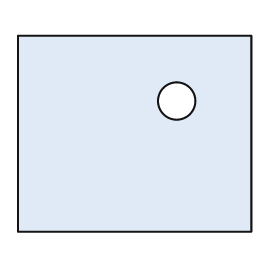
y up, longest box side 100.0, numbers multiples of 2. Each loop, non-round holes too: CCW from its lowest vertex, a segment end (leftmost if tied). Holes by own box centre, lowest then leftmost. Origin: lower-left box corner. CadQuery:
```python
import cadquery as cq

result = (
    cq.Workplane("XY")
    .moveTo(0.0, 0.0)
    .lineTo(100.0, 0.0)
    .lineTo(100.0, 84.0)
    .lineTo(0.0, 84.0)
    .close()
    .moveTo(68.0, 56.0)
    .circle(8.0)
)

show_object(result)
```